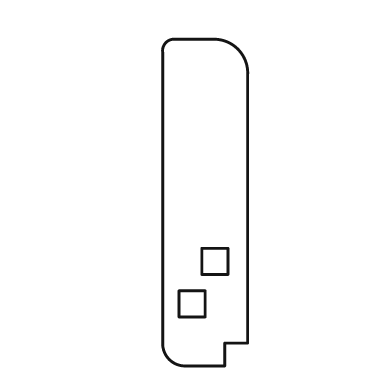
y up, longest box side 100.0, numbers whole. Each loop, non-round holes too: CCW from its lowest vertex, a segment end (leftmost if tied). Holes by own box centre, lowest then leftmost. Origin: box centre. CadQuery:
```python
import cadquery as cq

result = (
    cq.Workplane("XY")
    .moveTo(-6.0, -50.0)
    .lineTo(6.0, -50.0)
    .lineTo(6.0, -43.0)
    .lineTo(13.0, -43.0)
    .lineTo(13.0, 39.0)
    .threePointArc((10.0, 47.0), (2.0, 50.0))
    .lineTo(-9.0, 50.0)
    .threePointArc((-12.0, 49.0), (-13.0, 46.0))
    .lineTo(-13.0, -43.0)
    .threePointArc((-11.0, -48.0), (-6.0, -50.0))
    .close()
    .moveTo(-8.0, -35.0)
    .lineTo(0.0, -35.0)
    .lineTo(0.0, -27.0)
    .lineTo(-8.0, -27.0)
    .close()
    .moveTo(-1.0, -22.0)
    .lineTo(7.0, -22.0)
    .lineTo(7.0, -14.0)
    .lineTo(-1.0, -14.0)
    .close()
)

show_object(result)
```